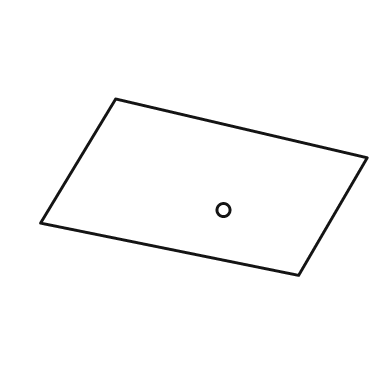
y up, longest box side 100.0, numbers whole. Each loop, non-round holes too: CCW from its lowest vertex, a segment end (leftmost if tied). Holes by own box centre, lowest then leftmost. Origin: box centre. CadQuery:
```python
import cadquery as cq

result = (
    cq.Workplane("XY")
    .moveTo(29.0, -27.0)
    .lineTo(50.0, 9.0)
    .lineTo(-27.0, 27.0)
    .lineTo(-50.0, -11.0)
    .close()
    .moveTo(6.0, -7.0)
    .circle(2.0)
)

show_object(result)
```